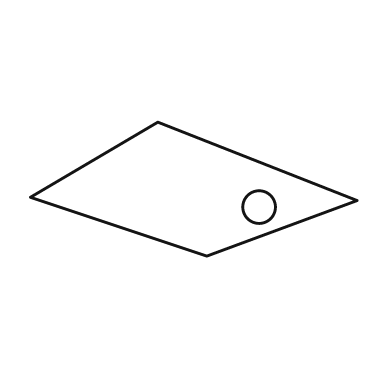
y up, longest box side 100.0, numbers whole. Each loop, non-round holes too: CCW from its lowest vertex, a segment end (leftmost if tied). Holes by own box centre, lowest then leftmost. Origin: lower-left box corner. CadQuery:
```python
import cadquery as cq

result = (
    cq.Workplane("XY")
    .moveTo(54.0, 0.0)
    .lineTo(100.0, 17.0)
    .lineTo(39.0, 41.0)
    .lineTo(0.0, 18.0)
    .close()
    .moveTo(70.0, 15.0)
    .circle(5.0)
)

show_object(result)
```